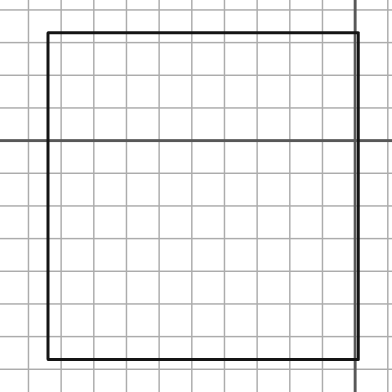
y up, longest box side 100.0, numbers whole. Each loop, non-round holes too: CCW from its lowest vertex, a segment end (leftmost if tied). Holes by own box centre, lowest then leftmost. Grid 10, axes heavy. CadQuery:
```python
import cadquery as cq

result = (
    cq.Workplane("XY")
    .moveTo(-94.0, -67.0)
    .lineTo(1.0, -67.0)
    .lineTo(1.0, 33.0)
    .lineTo(-94.0, 33.0)
    .close()
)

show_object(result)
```